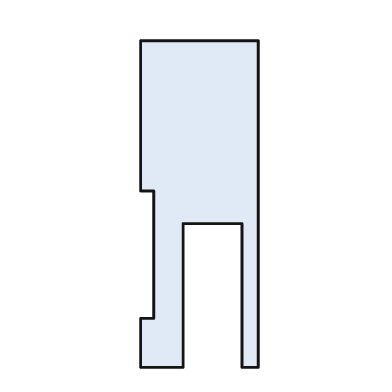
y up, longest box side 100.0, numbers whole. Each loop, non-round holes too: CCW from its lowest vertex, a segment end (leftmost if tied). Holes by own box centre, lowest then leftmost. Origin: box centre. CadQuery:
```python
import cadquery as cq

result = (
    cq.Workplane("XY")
    .moveTo(-18.0, -50.0)
    .lineTo(-5.0, -50.0)
    .lineTo(-5.0, -6.0)
    .lineTo(13.0, -6.0)
    .lineTo(13.0, -50.0)
    .lineTo(18.0, -50.0)
    .lineTo(18.0, 50.0)
    .lineTo(-18.0, 50.0)
    .lineTo(-18.0, 4.0)
    .lineTo(-14.0, 4.0)
    .lineTo(-14.0, -35.0)
    .lineTo(-18.0, -35.0)
    .close()
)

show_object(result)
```